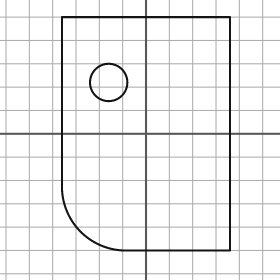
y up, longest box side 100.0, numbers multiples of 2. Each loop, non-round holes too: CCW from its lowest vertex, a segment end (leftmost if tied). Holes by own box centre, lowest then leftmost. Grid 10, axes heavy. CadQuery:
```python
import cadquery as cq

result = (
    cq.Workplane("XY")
    .moveTo(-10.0, -50.0)
    .lineTo(36.0, -50.0)
    .lineTo(36.0, 50.0)
    .lineTo(-36.0, 50.0)
    .lineTo(-36.0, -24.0)
    .threePointArc((-28.0, -42.0), (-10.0, -50.0))
    .close()
    .moveTo(-16.0, 22.0)
    .circle(8.0)
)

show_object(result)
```